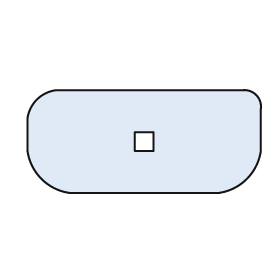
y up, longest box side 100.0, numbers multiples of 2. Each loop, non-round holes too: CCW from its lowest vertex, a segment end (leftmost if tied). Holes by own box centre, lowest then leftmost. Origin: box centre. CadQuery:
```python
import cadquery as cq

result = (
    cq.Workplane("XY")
    .moveTo(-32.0, -22.0)
    .lineTo(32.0, -22.0)
    .threePointArc((44.0, -16.0), (50.0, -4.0))
    .lineTo(50.0, 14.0)
    .threePointArc((48.0, 20.0), (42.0, 22.0))
    .lineTo(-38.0, 22.0)
    .threePointArc((-46.0, 18.0), (-50.0, 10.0))
    .lineTo(-50.0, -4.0)
    .threePointArc((-44.0, -16.0), (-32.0, -22.0))
    .close()
    .moveTo(-4.0, -4.0)
    .lineTo(4.0, -4.0)
    .lineTo(4.0, 4.0)
    .lineTo(-4.0, 4.0)
    .close()
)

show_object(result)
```